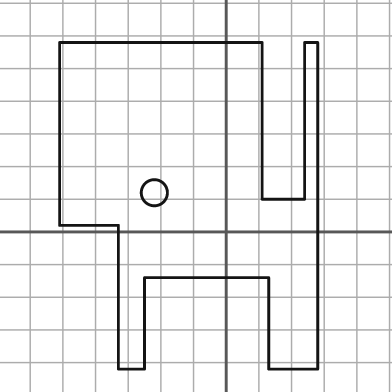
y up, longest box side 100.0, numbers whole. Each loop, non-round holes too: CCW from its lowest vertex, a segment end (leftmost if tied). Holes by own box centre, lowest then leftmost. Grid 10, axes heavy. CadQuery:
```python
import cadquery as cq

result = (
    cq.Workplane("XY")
    .moveTo(-33.0, -42.0)
    .lineTo(-25.0, -42.0)
    .lineTo(-25.0, -14.0)
    .lineTo(13.0, -14.0)
    .lineTo(13.0, -42.0)
    .lineTo(28.0, -42.0)
    .lineTo(28.0, 58.0)
    .lineTo(24.0, 58.0)
    .lineTo(24.0, 10.0)
    .lineTo(11.0, 10.0)
    .lineTo(11.0, 58.0)
    .lineTo(-51.0, 58.0)
    .lineTo(-51.0, 2.0)
    .lineTo(-33.0, 2.0)
    .close()
    .moveTo(-22.0, 12.0)
    .circle(4.0)
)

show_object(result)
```